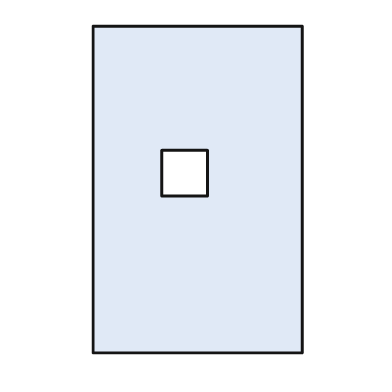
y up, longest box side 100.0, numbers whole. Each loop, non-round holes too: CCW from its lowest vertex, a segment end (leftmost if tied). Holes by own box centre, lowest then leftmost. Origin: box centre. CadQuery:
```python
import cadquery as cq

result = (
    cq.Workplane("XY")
    .moveTo(-32.0, -50.0)
    .lineTo(32.0, -50.0)
    .lineTo(32.0, 50.0)
    .lineTo(-32.0, 50.0)
    .close()
    .moveTo(-11.0, -2.0)
    .lineTo(3.0, -2.0)
    .lineTo(3.0, 12.0)
    .lineTo(-11.0, 12.0)
    .close()
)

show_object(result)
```